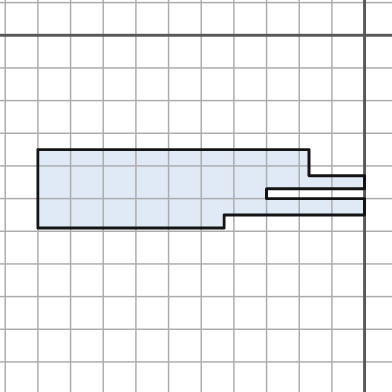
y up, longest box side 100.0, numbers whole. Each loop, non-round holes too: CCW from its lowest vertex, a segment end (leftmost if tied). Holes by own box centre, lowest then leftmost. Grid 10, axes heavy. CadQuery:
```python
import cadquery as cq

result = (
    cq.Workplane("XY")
    .moveTo(-100.0, -59.0)
    .lineTo(-43.0, -59.0)
    .lineTo(-43.0, -55.0)
    .lineTo(0.0, -55.0)
    .lineTo(0.0, -50.0)
    .lineTo(-30.0, -50.0)
    .lineTo(-30.0, -47.0)
    .lineTo(0.0, -47.0)
    .lineTo(0.0, -43.0)
    .lineTo(-17.0, -43.0)
    .lineTo(-17.0, -35.0)
    .lineTo(-100.0, -35.0)
    .close()
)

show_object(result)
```